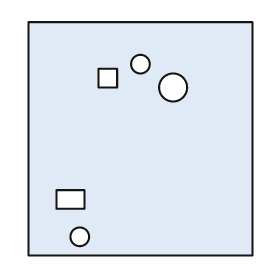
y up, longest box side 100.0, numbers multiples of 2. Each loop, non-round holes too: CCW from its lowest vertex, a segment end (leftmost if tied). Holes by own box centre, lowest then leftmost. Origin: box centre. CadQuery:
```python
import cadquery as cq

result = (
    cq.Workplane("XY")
    .moveTo(-48.0, -50.0)
    .lineTo(48.0, -50.0)
    .lineTo(48.0, 50.0)
    .lineTo(-48.0, 50.0)
    .close()
    .moveTo(-26.0, -42.0)
    .circle(4.0)
    .moveTo(-36.0, -30.0)
    .lineTo(-24.0, -30.0)
    .lineTo(-24.0, -22.0)
    .lineTo(-36.0, -22.0)
    .close()
    .moveTo(14.0, 22.0)
    .circle(6.0)
    .moveTo(-18.0, 22.0)
    .lineTo(-10.0, 22.0)
    .lineTo(-10.0, 30.0)
    .lineTo(-18.0, 30.0)
    .close()
    .moveTo(0.0, 32.0)
    .circle(4.0)
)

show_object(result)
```